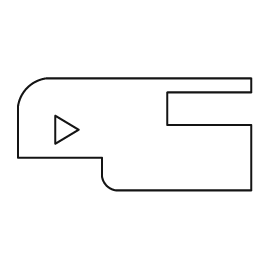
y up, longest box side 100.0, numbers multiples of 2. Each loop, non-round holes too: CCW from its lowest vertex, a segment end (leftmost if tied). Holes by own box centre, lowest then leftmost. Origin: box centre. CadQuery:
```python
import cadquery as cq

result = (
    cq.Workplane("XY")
    .moveTo(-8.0, -24.0)
    .lineTo(50.0, -24.0)
    .lineTo(50.0, 4.0)
    .lineTo(14.0, 4.0)
    .lineTo(14.0, 18.0)
    .lineTo(50.0, 18.0)
    .lineTo(50.0, 24.0)
    .lineTo(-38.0, 24.0)
    .threePointArc((-46.0, 20.0), (-50.0, 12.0))
    .lineTo(-50.0, -10.0)
    .lineTo(-14.0, -10.0)
    .lineTo(-14.0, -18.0)
    .threePointArc((-12.0, -22.0), (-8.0, -24.0))
    .close()
    .moveTo(-34.0, -4.0)
    .lineTo(-24.0, 2.0)
    .lineTo(-34.0, 8.0)
    .close()
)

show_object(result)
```